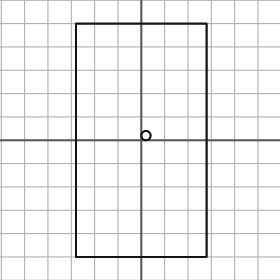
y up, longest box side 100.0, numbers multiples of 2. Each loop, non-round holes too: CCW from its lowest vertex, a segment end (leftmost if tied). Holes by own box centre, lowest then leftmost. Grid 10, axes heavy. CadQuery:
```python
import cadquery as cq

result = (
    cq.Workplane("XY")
    .moveTo(-28.0, -50.0)
    .lineTo(28.0, -50.0)
    .lineTo(28.0, 50.0)
    .lineTo(-28.0, 50.0)
    .close()
    .moveTo(2.0, 2.0)
    .circle(2.0)
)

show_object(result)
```